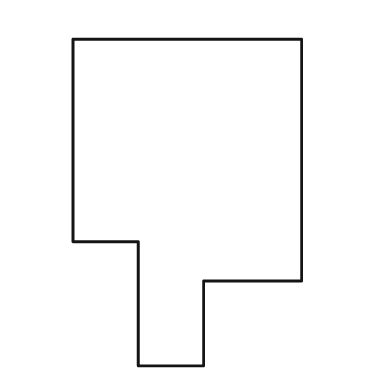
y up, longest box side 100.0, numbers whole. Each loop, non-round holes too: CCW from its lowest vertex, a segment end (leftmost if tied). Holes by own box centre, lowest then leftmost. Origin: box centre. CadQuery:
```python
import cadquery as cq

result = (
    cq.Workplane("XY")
    .moveTo(-15.0, -50.0)
    .lineTo(5.0, -50.0)
    .lineTo(5.0, -24.0)
    .lineTo(35.0, -24.0)
    .lineTo(35.0, 50.0)
    .lineTo(-35.0, 50.0)
    .lineTo(-35.0, -12.0)
    .lineTo(-15.0, -12.0)
    .close()
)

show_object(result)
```